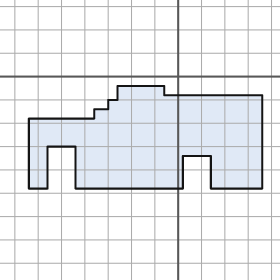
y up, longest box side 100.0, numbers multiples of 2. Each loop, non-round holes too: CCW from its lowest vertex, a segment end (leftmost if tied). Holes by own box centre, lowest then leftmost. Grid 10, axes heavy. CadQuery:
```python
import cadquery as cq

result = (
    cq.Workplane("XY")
    .moveTo(-64.0, -48.0)
    .lineTo(-56.0, -48.0)
    .lineTo(-56.0, -30.0)
    .lineTo(-44.0, -30.0)
    .lineTo(-44.0, -48.0)
    .lineTo(2.0, -48.0)
    .lineTo(2.0, -34.0)
    .lineTo(14.0, -34.0)
    .lineTo(14.0, -48.0)
    .lineTo(36.0, -48.0)
    .lineTo(36.0, -8.0)
    .lineTo(-6.0, -8.0)
    .lineTo(-6.0, -4.0)
    .lineTo(-26.0, -4.0)
    .lineTo(-26.0, -10.0)
    .lineTo(-30.0, -10.0)
    .lineTo(-30.0, -14.0)
    .lineTo(-36.0, -14.0)
    .lineTo(-36.0, -18.0)
    .lineTo(-64.0, -18.0)
    .close()
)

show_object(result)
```